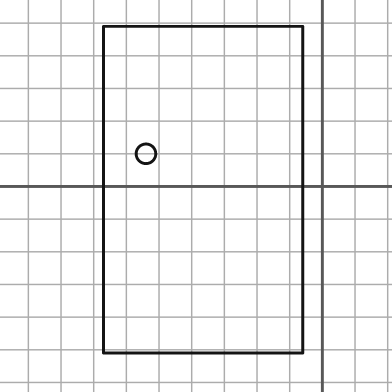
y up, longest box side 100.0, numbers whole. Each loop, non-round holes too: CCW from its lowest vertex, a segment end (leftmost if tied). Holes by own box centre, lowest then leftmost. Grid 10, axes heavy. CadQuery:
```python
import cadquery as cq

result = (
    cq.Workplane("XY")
    .moveTo(-67.0, -51.0)
    .lineTo(-6.0, -51.0)
    .lineTo(-6.0, 49.0)
    .lineTo(-67.0, 49.0)
    .close()
    .moveTo(-54.0, 10.0)
    .circle(3.0)
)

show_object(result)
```